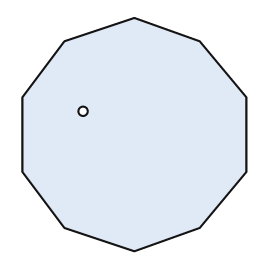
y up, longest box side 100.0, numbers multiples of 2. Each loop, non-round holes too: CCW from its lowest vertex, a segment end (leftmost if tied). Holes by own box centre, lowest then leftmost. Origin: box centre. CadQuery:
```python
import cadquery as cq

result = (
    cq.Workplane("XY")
    .moveTo(0.0, -50.0)
    .lineTo(28.0, -40.0)
    .lineTo(48.0, -16.0)
    .lineTo(48.0, 16.0)
    .lineTo(28.0, 40.0)
    .lineTo(0.0, 50.0)
    .lineTo(-30.0, 40.0)
    .lineTo(-48.0, 16.0)
    .lineTo(-48.0, -16.0)
    .lineTo(-30.0, -40.0)
    .close()
    .moveTo(-22.0, 10.0)
    .circle(2.0)
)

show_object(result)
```